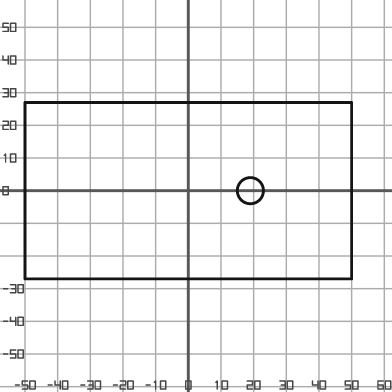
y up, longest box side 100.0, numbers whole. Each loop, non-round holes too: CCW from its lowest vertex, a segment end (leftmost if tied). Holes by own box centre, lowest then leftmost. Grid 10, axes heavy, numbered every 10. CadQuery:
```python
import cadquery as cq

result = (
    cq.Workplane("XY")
    .moveTo(-50.0, -27.0)
    .lineTo(50.0, -27.0)
    .lineTo(50.0, 27.0)
    .lineTo(-50.0, 27.0)
    .close()
    .moveTo(19.0, 0.0)
    .circle(4.0)
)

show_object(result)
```